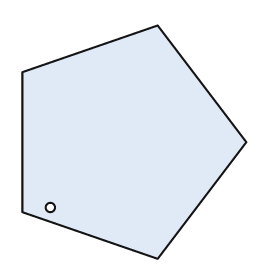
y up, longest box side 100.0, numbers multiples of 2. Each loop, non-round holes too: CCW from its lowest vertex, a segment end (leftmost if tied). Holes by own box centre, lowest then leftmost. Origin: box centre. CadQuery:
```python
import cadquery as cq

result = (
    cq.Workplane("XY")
    .moveTo(10.0, -50.0)
    .lineTo(48.0, 0.0)
    .lineTo(10.0, 50.0)
    .lineTo(-48.0, 30.0)
    .lineTo(-48.0, -30.0)
    .close()
    .moveTo(-36.0, -28.0)
    .circle(2.0)
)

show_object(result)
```